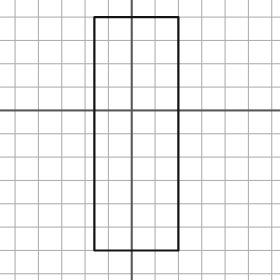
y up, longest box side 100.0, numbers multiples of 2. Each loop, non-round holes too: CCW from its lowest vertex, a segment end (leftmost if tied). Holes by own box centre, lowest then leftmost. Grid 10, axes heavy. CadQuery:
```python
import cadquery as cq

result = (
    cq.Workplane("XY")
    .moveTo(-16.0, -60.0)
    .lineTo(20.0, -60.0)
    .lineTo(20.0, 40.0)
    .lineTo(-16.0, 40.0)
    .close()
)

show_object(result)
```